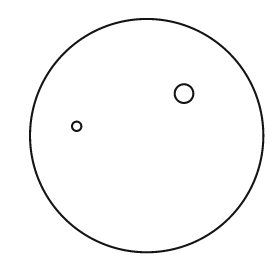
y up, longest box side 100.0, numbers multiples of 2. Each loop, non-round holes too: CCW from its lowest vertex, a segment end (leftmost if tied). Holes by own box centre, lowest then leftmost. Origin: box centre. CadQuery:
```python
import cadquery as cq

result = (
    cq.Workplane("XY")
    .moveTo(0.0, 0.0)
    .circle(50.0)
    .moveTo(-30.0, 4.0)
    .circle(2.0)
    .moveTo(16.0, 18.0)
    .circle(4.0)
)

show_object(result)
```